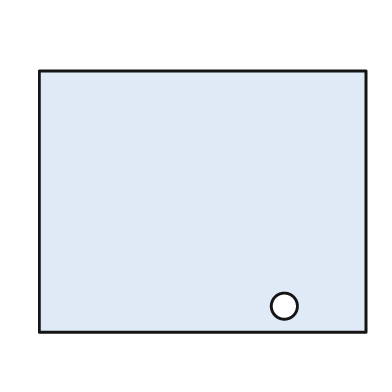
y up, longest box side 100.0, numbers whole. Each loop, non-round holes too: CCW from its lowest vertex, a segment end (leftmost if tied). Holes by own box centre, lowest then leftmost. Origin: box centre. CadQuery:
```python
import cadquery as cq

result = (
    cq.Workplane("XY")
    .moveTo(-50.0, -40.0)
    .lineTo(50.0, -40.0)
    .lineTo(50.0, 40.0)
    .lineTo(-50.0, 40.0)
    .close()
    .moveTo(25.0, -32.0)
    .circle(4.0)
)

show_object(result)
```